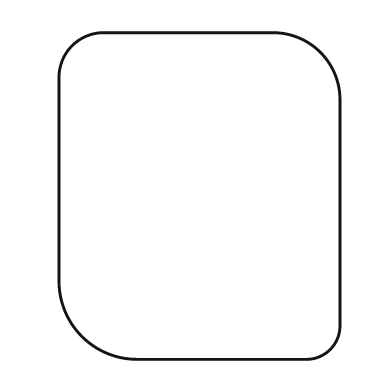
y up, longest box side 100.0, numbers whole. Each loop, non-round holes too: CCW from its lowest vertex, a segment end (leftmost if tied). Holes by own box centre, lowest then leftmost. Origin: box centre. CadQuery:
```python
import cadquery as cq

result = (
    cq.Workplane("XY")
    .moveTo(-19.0, -50.0)
    .lineTo(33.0, -50.0)
    .threePointArc((40.0, -47.0), (43.0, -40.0))
    .lineTo(43.0, 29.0)
    .threePointArc((37.0, 44.0), (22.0, 50.0))
    .lineTo(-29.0, 50.0)
    .threePointArc((-39.0, 46.0), (-43.0, 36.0))
    .lineTo(-43.0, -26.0)
    .threePointArc((-36.0, -43.0), (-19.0, -50.0))
    .close()
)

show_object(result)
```